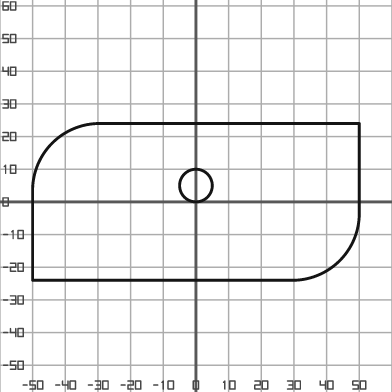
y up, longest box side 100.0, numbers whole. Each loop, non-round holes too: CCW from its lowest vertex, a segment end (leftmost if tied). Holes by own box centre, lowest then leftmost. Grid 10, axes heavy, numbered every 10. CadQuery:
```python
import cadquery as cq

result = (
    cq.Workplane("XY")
    .moveTo(-50.0, -24.0)
    .lineTo(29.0, -24.0)
    .threePointArc((44.0, -18.0), (50.0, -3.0))
    .lineTo(50.0, 24.0)
    .lineTo(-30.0, 24.0)
    .threePointArc((-44.0, 18.0), (-50.0, 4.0))
    .close()
    .moveTo(0.0, 5.0)
    .circle(5.0)
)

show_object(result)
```